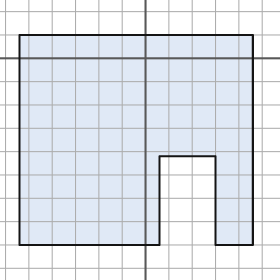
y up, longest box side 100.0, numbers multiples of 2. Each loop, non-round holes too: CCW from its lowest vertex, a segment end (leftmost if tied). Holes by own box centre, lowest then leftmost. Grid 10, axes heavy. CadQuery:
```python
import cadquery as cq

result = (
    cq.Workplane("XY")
    .moveTo(-54.0, -80.0)
    .lineTo(6.0, -80.0)
    .lineTo(6.0, -42.0)
    .lineTo(30.0, -42.0)
    .lineTo(30.0, -80.0)
    .lineTo(46.0, -80.0)
    .lineTo(46.0, 10.0)
    .lineTo(-54.0, 10.0)
    .close()
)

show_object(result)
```